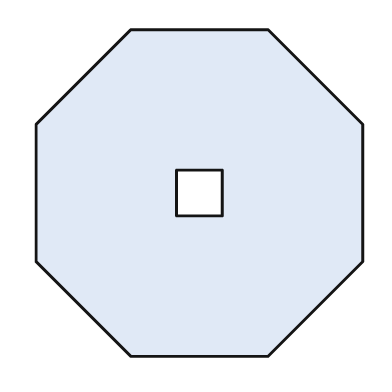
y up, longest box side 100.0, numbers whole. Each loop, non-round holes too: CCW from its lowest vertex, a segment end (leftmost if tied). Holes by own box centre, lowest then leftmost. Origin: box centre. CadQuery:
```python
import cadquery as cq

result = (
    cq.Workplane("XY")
    .moveTo(-21.0, -50.0)
    .lineTo(21.0, -50.0)
    .lineTo(50.0, -21.0)
    .lineTo(50.0, 21.0)
    .lineTo(21.0, 50.0)
    .lineTo(-21.0, 50.0)
    .lineTo(-50.0, 21.0)
    .lineTo(-50.0, -21.0)
    .close()
    .moveTo(-7.0, -7.0)
    .lineTo(7.0, -7.0)
    .lineTo(7.0, 7.0)
    .lineTo(-7.0, 7.0)
    .close()
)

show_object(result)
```